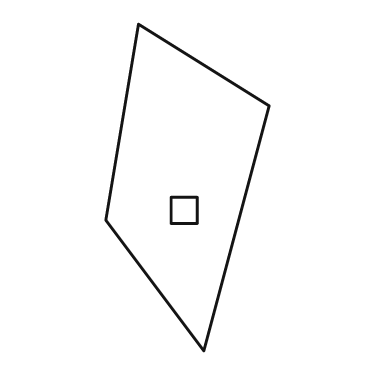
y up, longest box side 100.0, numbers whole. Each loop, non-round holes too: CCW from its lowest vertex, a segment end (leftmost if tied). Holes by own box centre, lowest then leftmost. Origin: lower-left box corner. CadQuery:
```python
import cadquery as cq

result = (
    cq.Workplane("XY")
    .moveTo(30.0, 0.0)
    .lineTo(50.0, 75.0)
    .lineTo(10.0, 100.0)
    .lineTo(0.0, 40.0)
    .close()
    .moveTo(20.0, 39.0)
    .lineTo(28.0, 39.0)
    .lineTo(28.0, 47.0)
    .lineTo(20.0, 47.0)
    .close()
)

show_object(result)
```